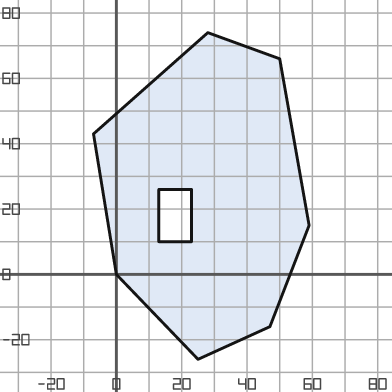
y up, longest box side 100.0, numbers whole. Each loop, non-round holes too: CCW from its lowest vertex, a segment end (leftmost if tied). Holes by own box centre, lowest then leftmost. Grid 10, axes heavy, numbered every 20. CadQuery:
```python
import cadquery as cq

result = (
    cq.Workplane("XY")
    .moveTo(25.0, -26.0)
    .lineTo(47.0, -16.0)
    .lineTo(59.0, 15.0)
    .lineTo(50.0, 66.0)
    .lineTo(28.0, 74.0)
    .lineTo(-7.0, 43.0)
    .lineTo(0.0, 0.0)
    .close()
    .moveTo(13.0, 10.0)
    .lineTo(23.0, 10.0)
    .lineTo(23.0, 26.0)
    .lineTo(13.0, 26.0)
    .close()
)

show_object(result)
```